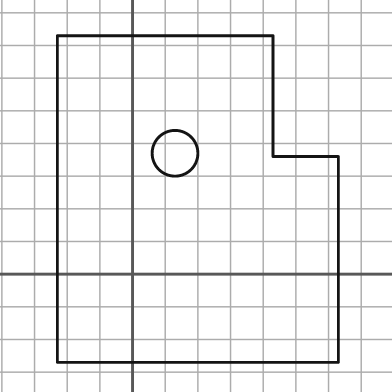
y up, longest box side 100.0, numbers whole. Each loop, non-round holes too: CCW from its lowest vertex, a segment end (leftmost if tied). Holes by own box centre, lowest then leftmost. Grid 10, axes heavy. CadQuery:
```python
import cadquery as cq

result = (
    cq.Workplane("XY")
    .moveTo(-23.0, -27.0)
    .lineTo(63.0, -27.0)
    .lineTo(63.0, 36.0)
    .lineTo(43.0, 36.0)
    .lineTo(43.0, 73.0)
    .lineTo(-23.0, 73.0)
    .close()
    .moveTo(13.0, 37.0)
    .circle(7.0)
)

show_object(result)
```